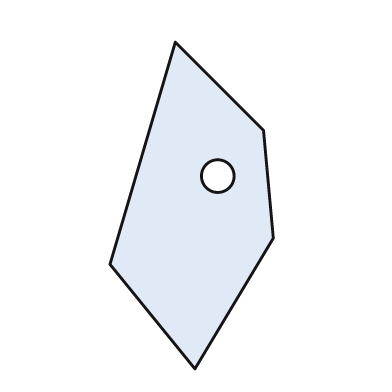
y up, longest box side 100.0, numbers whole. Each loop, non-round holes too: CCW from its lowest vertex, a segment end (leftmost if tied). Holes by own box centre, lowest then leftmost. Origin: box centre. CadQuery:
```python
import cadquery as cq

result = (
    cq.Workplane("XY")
    .moveTo(1.0, -50.0)
    .lineTo(25.0, -10.0)
    .lineTo(22.0, 23.0)
    .lineTo(-5.0, 50.0)
    .lineTo(-25.0, -18.0)
    .close()
    .moveTo(8.0, 9.0)
    .circle(5.0)
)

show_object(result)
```